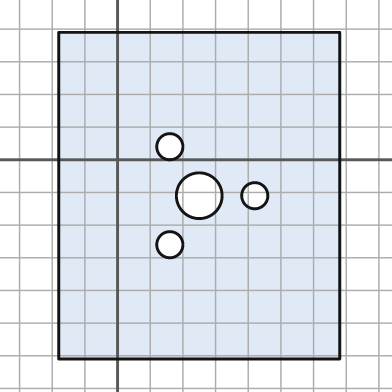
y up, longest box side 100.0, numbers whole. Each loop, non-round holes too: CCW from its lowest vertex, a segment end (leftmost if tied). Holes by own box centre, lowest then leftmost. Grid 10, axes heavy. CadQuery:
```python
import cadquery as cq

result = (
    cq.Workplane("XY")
    .moveTo(-18.0, -61.0)
    .lineTo(68.0, -61.0)
    .lineTo(68.0, 39.0)
    .lineTo(-18.0, 39.0)
    .close()
    .moveTo(16.0, -26.0)
    .circle(4.0)
    .moveTo(25.0, -11.0)
    .circle(7.0)
    .moveTo(42.0, -11.0)
    .circle(4.0)
    .moveTo(16.0, 4.0)
    .circle(4.0)
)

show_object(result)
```